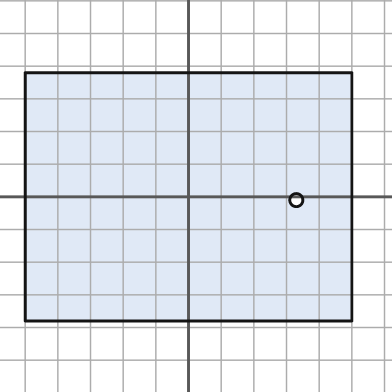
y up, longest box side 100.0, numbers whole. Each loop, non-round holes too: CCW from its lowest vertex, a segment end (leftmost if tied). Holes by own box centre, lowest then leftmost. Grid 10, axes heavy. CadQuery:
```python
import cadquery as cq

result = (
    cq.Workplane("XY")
    .moveTo(-50.0, -38.0)
    .lineTo(50.0, -38.0)
    .lineTo(50.0, 38.0)
    .lineTo(-50.0, 38.0)
    .close()
    .moveTo(33.0, -1.0)
    .circle(2.0)
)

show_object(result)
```